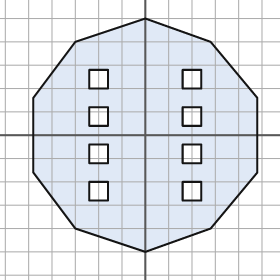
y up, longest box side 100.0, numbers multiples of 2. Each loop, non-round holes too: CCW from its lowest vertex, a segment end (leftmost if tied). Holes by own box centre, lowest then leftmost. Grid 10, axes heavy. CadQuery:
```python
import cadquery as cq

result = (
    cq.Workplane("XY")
    .moveTo(0.0, -50.0)
    .lineTo(28.0, -40.0)
    .lineTo(48.0, -16.0)
    .lineTo(48.0, 16.0)
    .lineTo(28.0, 40.0)
    .lineTo(0.0, 50.0)
    .lineTo(-30.0, 40.0)
    .lineTo(-48.0, 16.0)
    .lineTo(-48.0, -16.0)
    .lineTo(-30.0, -40.0)
    .close()
    .moveTo(-24.0, -28.0)
    .lineTo(-16.0, -28.0)
    .lineTo(-16.0, -20.0)
    .lineTo(-24.0, -20.0)
    .close()
    .moveTo(16.0, -28.0)
    .lineTo(24.0, -28.0)
    .lineTo(24.0, -20.0)
    .lineTo(16.0, -20.0)
    .close()
    .moveTo(-24.0, -12.0)
    .lineTo(-16.0, -12.0)
    .lineTo(-16.0, -4.0)
    .lineTo(-24.0, -4.0)
    .close()
    .moveTo(16.0, -12.0)
    .lineTo(24.0, -12.0)
    .lineTo(24.0, -4.0)
    .lineTo(16.0, -4.0)
    .close()
    .moveTo(-24.0, 4.0)
    .lineTo(-16.0, 4.0)
    .lineTo(-16.0, 12.0)
    .lineTo(-24.0, 12.0)
    .close()
    .moveTo(16.0, 4.0)
    .lineTo(24.0, 4.0)
    .lineTo(24.0, 12.0)
    .lineTo(16.0, 12.0)
    .close()
    .moveTo(-24.0, 20.0)
    .lineTo(-16.0, 20.0)
    .lineTo(-16.0, 28.0)
    .lineTo(-24.0, 28.0)
    .close()
    .moveTo(16.0, 20.0)
    .lineTo(24.0, 20.0)
    .lineTo(24.0, 28.0)
    .lineTo(16.0, 28.0)
    .close()
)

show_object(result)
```